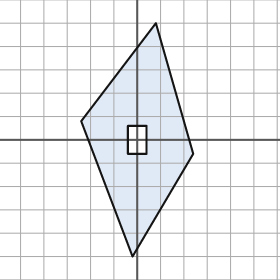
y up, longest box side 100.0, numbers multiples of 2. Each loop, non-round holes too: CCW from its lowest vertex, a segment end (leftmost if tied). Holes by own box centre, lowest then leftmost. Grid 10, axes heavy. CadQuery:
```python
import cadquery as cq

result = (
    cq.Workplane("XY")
    .moveTo(-2.0, -50.0)
    .lineTo(24.0, -6.0)
    .lineTo(8.0, 50.0)
    .lineTo(-24.0, 8.0)
    .close()
    .moveTo(-4.0, -6.0)
    .lineTo(4.0, -6.0)
    .lineTo(4.0, 6.0)
    .lineTo(-4.0, 6.0)
    .close()
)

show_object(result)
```